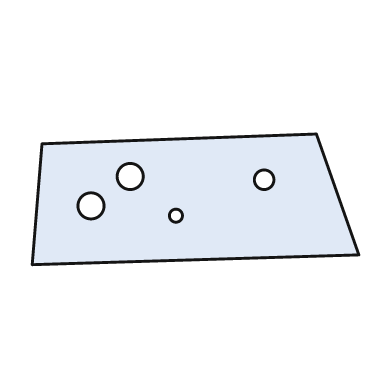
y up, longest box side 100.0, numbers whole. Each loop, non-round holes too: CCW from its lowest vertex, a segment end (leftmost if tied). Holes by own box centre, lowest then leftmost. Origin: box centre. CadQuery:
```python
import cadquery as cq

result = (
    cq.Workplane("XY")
    .moveTo(-50.0, -20.0)
    .lineTo(50.0, -17.0)
    .lineTo(37.0, 20.0)
    .lineTo(-47.0, 17.0)
    .close()
    .moveTo(-6.0, -5.0)
    .circle(2.0)
    .moveTo(-32.0, -2.0)
    .circle(4.0)
    .moveTo(21.0, 6.0)
    .circle(3.0)
    .moveTo(-20.0, 7.0)
    .circle(4.0)
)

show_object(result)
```